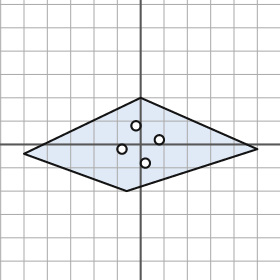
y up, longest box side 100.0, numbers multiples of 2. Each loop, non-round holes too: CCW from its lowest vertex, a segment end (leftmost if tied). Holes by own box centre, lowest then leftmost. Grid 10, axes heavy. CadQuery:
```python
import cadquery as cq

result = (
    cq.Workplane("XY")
    .moveTo(-6.0, -20.0)
    .lineTo(50.0, -2.0)
    .lineTo(0.0, 20.0)
    .lineTo(-50.0, -4.0)
    .close()
    .moveTo(2.0, -8.0)
    .circle(2.0)
    .moveTo(-8.0, -2.0)
    .circle(2.0)
    .moveTo(8.0, 2.0)
    .circle(2.0)
    .moveTo(-2.0, 8.0)
    .circle(2.0)
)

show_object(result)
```